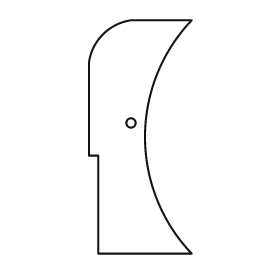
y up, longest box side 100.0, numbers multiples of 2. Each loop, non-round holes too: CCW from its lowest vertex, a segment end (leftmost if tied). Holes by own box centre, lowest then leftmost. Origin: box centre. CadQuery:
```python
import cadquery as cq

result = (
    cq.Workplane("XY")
    .moveTo(-18.0, -50.0)
    .lineTo(22.0, -50.0)
    .threePointArc((2.0, 0.0), (22.0, 50.0))
    .lineTo(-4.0, 50.0)
    .threePointArc((-16.0, 44.0), (-22.0, 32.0))
    .lineTo(-22.0, -8.0)
    .lineTo(-18.0, -8.0)
    .close()
    .moveTo(-4.0, 6.0)
    .circle(2.0)
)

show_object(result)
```